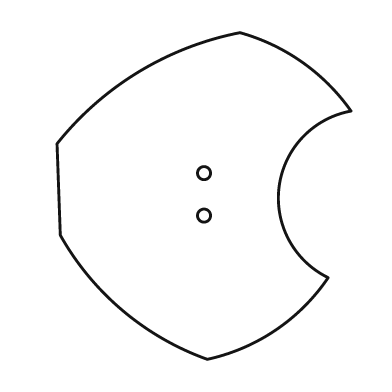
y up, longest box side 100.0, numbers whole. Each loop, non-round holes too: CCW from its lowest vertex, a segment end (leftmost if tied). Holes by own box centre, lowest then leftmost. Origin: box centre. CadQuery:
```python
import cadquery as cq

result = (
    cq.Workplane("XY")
    .moveTo(1.0, -50.0)
    .threePointArc((22.0, -41.0), (38.0, -25.0))
    .threePointArc((23.0, 3.0), (45.0, 26.0))
    .threePointArc((30.0, 41.0), (11.0, 50.0))
    .threePointArc((-20.0, 38.0), (-45.0, 16.0))
    .lineTo(-44.0, -12.0)
    .threePointArc((-25.0, -35.0), (1.0, -50.0))
    .close()
    .moveTo(0.0, -6.0)
    .circle(2.0)
    .moveTo(0.0, 7.0)
    .circle(2.0)
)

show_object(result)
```